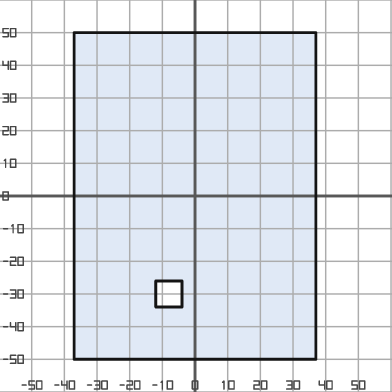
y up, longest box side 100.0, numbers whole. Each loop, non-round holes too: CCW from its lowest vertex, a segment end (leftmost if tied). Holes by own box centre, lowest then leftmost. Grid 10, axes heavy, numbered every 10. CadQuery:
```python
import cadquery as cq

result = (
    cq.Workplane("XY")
    .moveTo(-37.0, -50.0)
    .lineTo(37.0, -50.0)
    .lineTo(37.0, 50.0)
    .lineTo(-37.0, 50.0)
    .close()
    .moveTo(-12.0, -34.0)
    .lineTo(-4.0, -34.0)
    .lineTo(-4.0, -26.0)
    .lineTo(-12.0, -26.0)
    .close()
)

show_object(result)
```